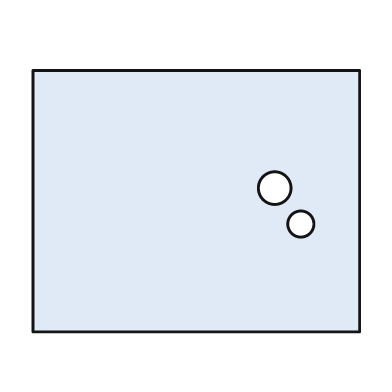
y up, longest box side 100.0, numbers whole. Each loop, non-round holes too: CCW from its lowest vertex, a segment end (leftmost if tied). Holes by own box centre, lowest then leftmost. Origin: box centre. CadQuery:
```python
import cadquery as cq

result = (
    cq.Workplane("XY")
    .moveTo(-50.0, -40.0)
    .lineTo(50.0, -40.0)
    .lineTo(50.0, 40.0)
    .lineTo(-50.0, 40.0)
    .close()
    .moveTo(32.0, -7.0)
    .circle(4.0)
    .moveTo(24.0, 4.0)
    .circle(5.0)
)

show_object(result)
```